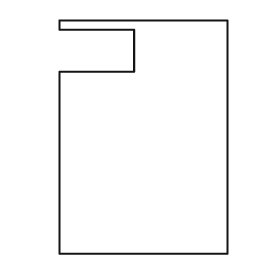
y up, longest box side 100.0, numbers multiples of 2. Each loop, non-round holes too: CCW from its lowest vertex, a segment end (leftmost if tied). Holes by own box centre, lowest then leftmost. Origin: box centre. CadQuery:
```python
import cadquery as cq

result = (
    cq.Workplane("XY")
    .moveTo(-36.0, -50.0)
    .lineTo(36.0, -50.0)
    .lineTo(36.0, 50.0)
    .lineTo(-36.0, 50.0)
    .lineTo(-36.0, 46.0)
    .lineTo(-4.0, 46.0)
    .lineTo(-4.0, 28.0)
    .lineTo(-36.0, 28.0)
    .close()
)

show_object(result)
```